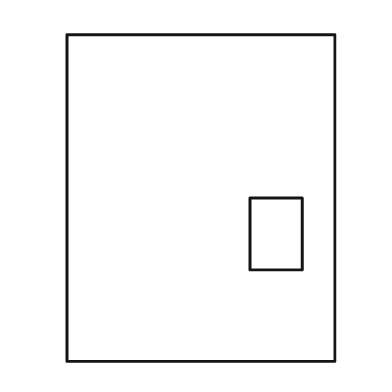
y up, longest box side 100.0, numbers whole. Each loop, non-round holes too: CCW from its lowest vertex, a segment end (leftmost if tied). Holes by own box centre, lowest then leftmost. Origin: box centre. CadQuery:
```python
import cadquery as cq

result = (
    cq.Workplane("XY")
    .moveTo(-41.0, -50.0)
    .lineTo(41.0, -50.0)
    .lineTo(41.0, 50.0)
    .lineTo(-41.0, 50.0)
    .close()
    .moveTo(15.0, -22.0)
    .lineTo(31.0, -22.0)
    .lineTo(31.0, 0.0)
    .lineTo(15.0, 0.0)
    .close()
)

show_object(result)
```